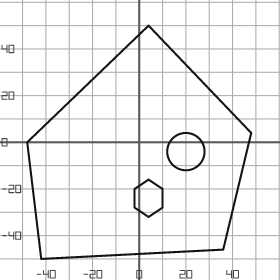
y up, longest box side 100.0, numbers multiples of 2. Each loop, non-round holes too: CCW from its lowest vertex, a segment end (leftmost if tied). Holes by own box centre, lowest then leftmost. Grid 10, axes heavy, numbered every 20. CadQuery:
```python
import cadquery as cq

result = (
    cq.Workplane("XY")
    .moveTo(-42.0, -50.0)
    .lineTo(36.0, -46.0)
    .lineTo(48.0, 4.0)
    .lineTo(4.0, 50.0)
    .lineTo(-48.0, 0.0)
    .close()
    .moveTo(4.0, -32.0)
    .lineTo(10.0, -28.0)
    .lineTo(10.0, -20.0)
    .lineTo(4.0, -16.0)
    .lineTo(-2.0, -20.0)
    .lineTo(-2.0, -28.0)
    .close()
    .moveTo(20.0, -4.0)
    .circle(8.0)
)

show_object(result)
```